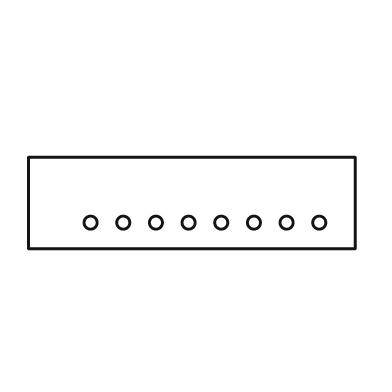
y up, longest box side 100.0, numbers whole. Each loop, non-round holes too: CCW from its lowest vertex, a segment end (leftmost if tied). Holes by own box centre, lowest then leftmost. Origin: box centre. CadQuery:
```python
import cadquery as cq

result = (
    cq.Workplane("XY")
    .moveTo(-50.0, -14.0)
    .lineTo(50.0, -14.0)
    .lineTo(50.0, 14.0)
    .lineTo(-50.0, 14.0)
    .close()
    .moveTo(-31.0, -6.0)
    .circle(2.0)
    .moveTo(-21.0, -6.0)
    .circle(2.0)
    .moveTo(-11.0, -6.0)
    .circle(2.0)
    .moveTo(-1.0, -6.0)
    .circle(2.0)
    .moveTo(9.0, -6.0)
    .circle(2.0)
    .moveTo(19.0, -6.0)
    .circle(2.0)
    .moveTo(29.0, -6.0)
    .circle(2.0)
    .moveTo(39.0, -6.0)
    .circle(2.0)
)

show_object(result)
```